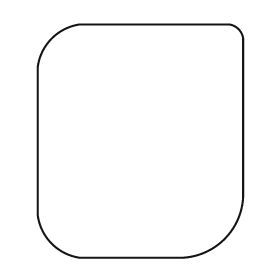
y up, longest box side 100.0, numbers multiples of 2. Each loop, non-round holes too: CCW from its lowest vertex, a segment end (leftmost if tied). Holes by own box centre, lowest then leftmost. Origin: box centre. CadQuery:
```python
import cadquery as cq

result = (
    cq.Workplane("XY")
    .moveTo(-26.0, -50.0)
    .lineTo(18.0, -50.0)
    .threePointArc((36.0, -42.0), (44.0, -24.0))
    .lineTo(44.0, 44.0)
    .threePointArc((42.0, 48.0), (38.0, 50.0))
    .lineTo(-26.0, 50.0)
    .threePointArc((-38.0, 44.0), (-44.0, 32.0))
    .lineTo(-44.0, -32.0)
    .threePointArc((-38.0, -44.0), (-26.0, -50.0))
    .close()
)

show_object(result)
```